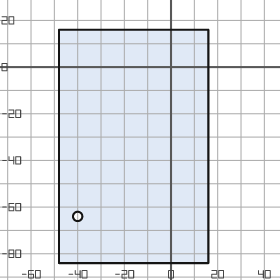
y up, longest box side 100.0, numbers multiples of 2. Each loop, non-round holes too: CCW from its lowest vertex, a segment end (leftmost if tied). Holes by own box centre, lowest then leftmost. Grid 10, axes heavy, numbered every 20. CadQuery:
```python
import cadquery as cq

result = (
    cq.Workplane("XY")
    .moveTo(-48.0, -84.0)
    .lineTo(16.0, -84.0)
    .lineTo(16.0, 16.0)
    .lineTo(-48.0, 16.0)
    .close()
    .moveTo(-40.0, -64.0)
    .circle(2.0)
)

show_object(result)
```